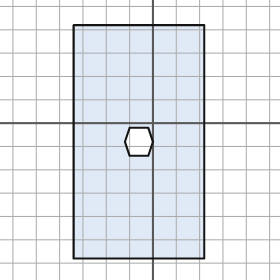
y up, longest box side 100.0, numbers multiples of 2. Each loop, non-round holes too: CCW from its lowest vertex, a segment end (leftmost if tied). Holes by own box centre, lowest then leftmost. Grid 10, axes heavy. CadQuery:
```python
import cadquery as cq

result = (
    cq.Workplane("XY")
    .moveTo(-34.0, -58.0)
    .lineTo(22.0, -58.0)
    .lineTo(22.0, 42.0)
    .lineTo(-34.0, 42.0)
    .close()
    .moveTo(-10.0, -14.0)
    .lineTo(-2.0, -14.0)
    .lineTo(0.0, -8.0)
    .lineTo(-2.0, -2.0)
    .lineTo(-10.0, -2.0)
    .lineTo(-12.0, -8.0)
    .close()
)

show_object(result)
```